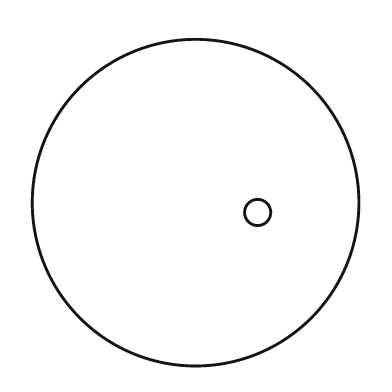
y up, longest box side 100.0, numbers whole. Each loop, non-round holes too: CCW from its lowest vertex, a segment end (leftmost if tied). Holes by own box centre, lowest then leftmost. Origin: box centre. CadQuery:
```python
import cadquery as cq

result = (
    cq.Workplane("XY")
    .moveTo(0.0, 0.0)
    .circle(50.0)
    .moveTo(19.0, -3.0)
    .circle(4.0)
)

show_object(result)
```